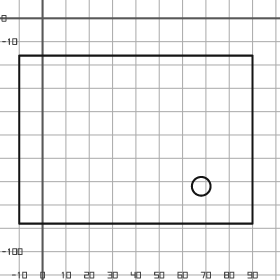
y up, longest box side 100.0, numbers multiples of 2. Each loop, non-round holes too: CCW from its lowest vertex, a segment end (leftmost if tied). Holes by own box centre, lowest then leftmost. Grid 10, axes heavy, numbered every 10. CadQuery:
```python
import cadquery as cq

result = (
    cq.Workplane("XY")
    .moveTo(-10.0, -88.0)
    .lineTo(90.0, -88.0)
    .lineTo(90.0, -16.0)
    .lineTo(-10.0, -16.0)
    .close()
    .moveTo(68.0, -72.0)
    .circle(4.0)
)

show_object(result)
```